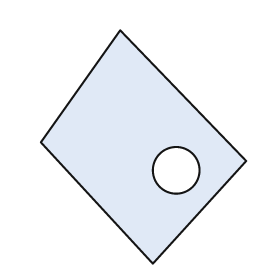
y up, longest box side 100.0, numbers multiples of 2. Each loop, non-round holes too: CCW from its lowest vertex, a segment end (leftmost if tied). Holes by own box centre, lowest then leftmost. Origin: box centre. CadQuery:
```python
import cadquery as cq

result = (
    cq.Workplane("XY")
    .moveTo(4.0, -50.0)
    .lineTo(44.0, -6.0)
    .lineTo(-10.0, 50.0)
    .lineTo(-44.0, 2.0)
    .close()
    .moveTo(14.0, -10.0)
    .circle(10.0)
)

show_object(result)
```